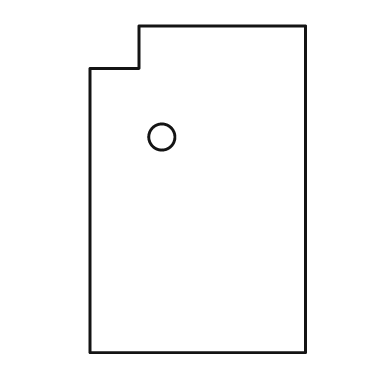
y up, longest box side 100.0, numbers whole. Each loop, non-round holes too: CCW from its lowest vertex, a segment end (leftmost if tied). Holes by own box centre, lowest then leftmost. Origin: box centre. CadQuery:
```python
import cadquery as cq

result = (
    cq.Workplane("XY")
    .moveTo(-33.0, -50.0)
    .lineTo(33.0, -50.0)
    .lineTo(33.0, 50.0)
    .lineTo(-18.0, 50.0)
    .lineTo(-18.0, 37.0)
    .lineTo(-33.0, 37.0)
    .close()
    .moveTo(-11.0, 16.0)
    .circle(4.0)
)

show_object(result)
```